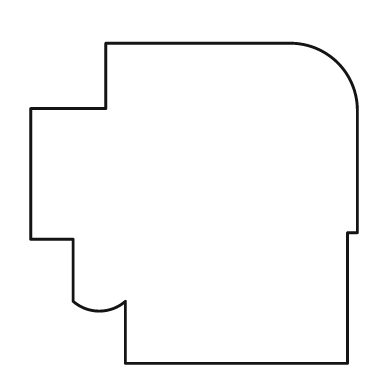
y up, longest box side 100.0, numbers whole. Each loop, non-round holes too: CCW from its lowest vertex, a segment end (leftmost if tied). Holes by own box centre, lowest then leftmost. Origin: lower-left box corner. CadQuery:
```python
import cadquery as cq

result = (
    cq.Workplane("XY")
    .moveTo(29.0, 0.0)
    .lineTo(97.0, 0.0)
    .lineTo(97.0, 40.0)
    .lineTo(100.0, 40.0)
    .lineTo(100.0, 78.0)
    .threePointArc((94.0, 92.0), (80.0, 98.0))
    .lineTo(23.0, 98.0)
    .lineTo(23.0, 78.0)
    .lineTo(0.0, 78.0)
    .lineTo(0.0, 38.0)
    .lineTo(13.0, 38.0)
    .lineTo(13.0, 19.0)
    .threePointArc((21.0, 16.0), (29.0, 19.0))
    .close()
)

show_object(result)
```